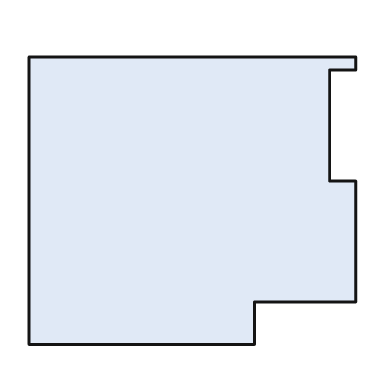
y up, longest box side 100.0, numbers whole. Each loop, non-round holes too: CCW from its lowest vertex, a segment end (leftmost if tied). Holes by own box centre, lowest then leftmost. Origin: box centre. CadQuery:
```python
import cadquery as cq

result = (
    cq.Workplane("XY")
    .moveTo(-50.0, -44.0)
    .lineTo(19.0, -44.0)
    .lineTo(19.0, -31.0)
    .lineTo(50.0, -31.0)
    .lineTo(50.0, 6.0)
    .lineTo(42.0, 6.0)
    .lineTo(42.0, 40.0)
    .lineTo(50.0, 40.0)
    .lineTo(50.0, 44.0)
    .lineTo(-50.0, 44.0)
    .close()
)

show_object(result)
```